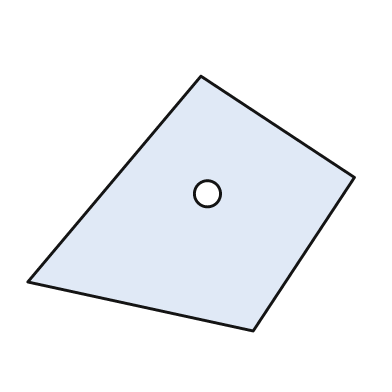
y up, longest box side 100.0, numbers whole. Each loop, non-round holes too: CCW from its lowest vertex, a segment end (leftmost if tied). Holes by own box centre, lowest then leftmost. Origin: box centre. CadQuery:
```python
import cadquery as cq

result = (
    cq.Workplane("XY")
    .moveTo(19.0, -39.0)
    .lineTo(50.0, 8.0)
    .lineTo(3.0, 39.0)
    .lineTo(-50.0, -24.0)
    .close()
    .moveTo(5.0, 3.0)
    .circle(4.0)
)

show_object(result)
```